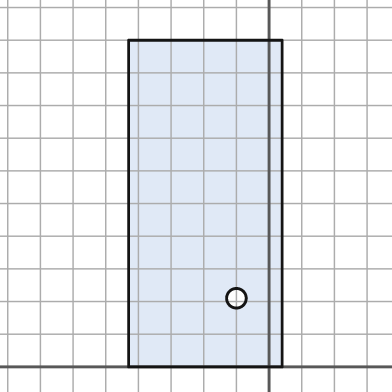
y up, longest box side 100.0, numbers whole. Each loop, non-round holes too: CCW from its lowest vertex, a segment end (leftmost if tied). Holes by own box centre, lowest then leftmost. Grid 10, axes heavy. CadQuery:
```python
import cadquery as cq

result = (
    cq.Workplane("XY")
    .moveTo(-43.0, 0.0)
    .lineTo(4.0, 0.0)
    .lineTo(4.0, 100.0)
    .lineTo(-43.0, 100.0)
    .close()
    .moveTo(-10.0, 21.0)
    .circle(3.0)
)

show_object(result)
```